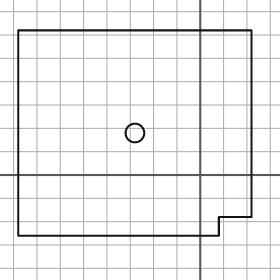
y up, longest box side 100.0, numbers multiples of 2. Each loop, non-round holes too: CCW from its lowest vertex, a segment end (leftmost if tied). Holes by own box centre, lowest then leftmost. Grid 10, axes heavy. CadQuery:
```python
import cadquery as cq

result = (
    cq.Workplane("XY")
    .moveTo(-78.0, -26.0)
    .lineTo(8.0, -26.0)
    .lineTo(8.0, -18.0)
    .lineTo(22.0, -18.0)
    .lineTo(22.0, 62.0)
    .lineTo(-78.0, 62.0)
    .close()
    .moveTo(-28.0, 18.0)
    .circle(4.0)
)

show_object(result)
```